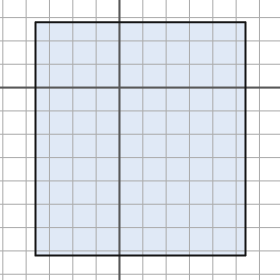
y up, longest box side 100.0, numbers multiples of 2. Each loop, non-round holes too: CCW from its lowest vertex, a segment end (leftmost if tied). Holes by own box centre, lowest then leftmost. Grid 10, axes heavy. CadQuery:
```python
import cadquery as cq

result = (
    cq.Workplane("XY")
    .moveTo(-36.0, -72.0)
    .lineTo(54.0, -72.0)
    .lineTo(54.0, 28.0)
    .lineTo(-36.0, 28.0)
    .close()
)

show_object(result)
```